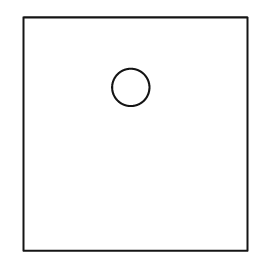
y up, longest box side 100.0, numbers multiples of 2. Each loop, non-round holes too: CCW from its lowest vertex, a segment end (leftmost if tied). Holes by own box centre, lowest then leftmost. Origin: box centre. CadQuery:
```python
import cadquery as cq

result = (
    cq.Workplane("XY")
    .moveTo(-48.0, -50.0)
    .lineTo(48.0, -50.0)
    .lineTo(48.0, 50.0)
    .lineTo(-48.0, 50.0)
    .close()
    .moveTo(-2.0, 20.0)
    .circle(8.0)
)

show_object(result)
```